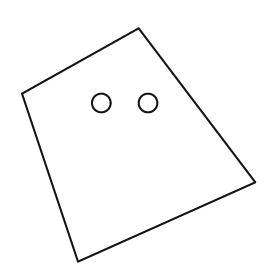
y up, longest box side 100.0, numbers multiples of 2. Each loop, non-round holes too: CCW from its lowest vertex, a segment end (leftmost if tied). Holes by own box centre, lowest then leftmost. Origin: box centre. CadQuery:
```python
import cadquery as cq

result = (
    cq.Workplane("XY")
    .moveTo(-26.0, -50.0)
    .lineTo(50.0, -16.0)
    .lineTo(0.0, 50.0)
    .lineTo(-50.0, 22.0)
    .close()
    .moveTo(-16.0, 18.0)
    .circle(4.0)
    .moveTo(4.0, 18.0)
    .circle(4.0)
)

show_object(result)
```